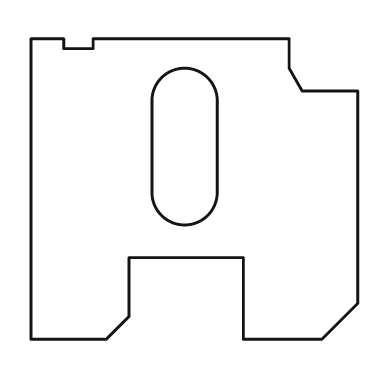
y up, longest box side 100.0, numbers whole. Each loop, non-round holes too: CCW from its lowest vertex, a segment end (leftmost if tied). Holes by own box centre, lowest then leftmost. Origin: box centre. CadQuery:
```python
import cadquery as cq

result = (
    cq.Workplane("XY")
    .moveTo(-50.0, -46.0)
    .lineTo(-27.0, -46.0)
    .lineTo(-20.0, -39.0)
    .lineTo(-20.0, -21.0)
    .lineTo(15.0, -21.0)
    .lineTo(15.0, -46.0)
    .lineTo(39.0, -46.0)
    .lineTo(50.0, -35.0)
    .lineTo(50.0, 30.0)
    .lineTo(33.0, 30.0)
    .lineTo(29.0, 37.0)
    .lineTo(29.0, 46.0)
    .lineTo(-31.0, 46.0)
    .lineTo(-31.0, 43.0)
    .lineTo(-40.0, 43.0)
    .lineTo(-40.0, 46.0)
    .lineTo(-50.0, 46.0)
    .close()
    .moveTo(-13.0, -1.0)
    .threePointArc((-3.0, -11.0), (7.0, -1.0))
    .lineTo(7.0, 27.0)
    .threePointArc((-3.0, 37.0), (-13.0, 27.0))
    .close()
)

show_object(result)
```